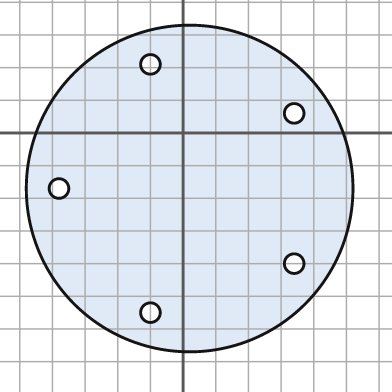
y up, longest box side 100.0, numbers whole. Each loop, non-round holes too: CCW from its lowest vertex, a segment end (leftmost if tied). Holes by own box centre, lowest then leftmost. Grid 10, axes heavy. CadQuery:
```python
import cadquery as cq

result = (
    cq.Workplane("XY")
    .moveTo(2.0, -17.0)
    .circle(50.0)
    .moveTo(-10.0, -55.0)
    .circle(3.0)
    .moveTo(34.0, -40.0)
    .circle(3.0)
    .moveTo(-38.0, -17.0)
    .circle(3.0)
    .moveTo(34.0, 6.0)
    .circle(3.0)
    .moveTo(-10.0, 21.0)
    .circle(3.0)
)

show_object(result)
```